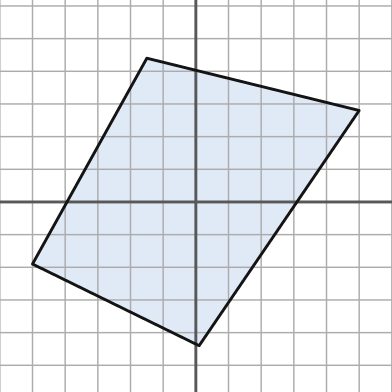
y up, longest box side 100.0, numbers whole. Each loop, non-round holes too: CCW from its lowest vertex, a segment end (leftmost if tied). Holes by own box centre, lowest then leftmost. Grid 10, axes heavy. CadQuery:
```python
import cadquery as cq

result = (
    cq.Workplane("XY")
    .moveTo(1.0, -44.0)
    .lineTo(50.0, 28.0)
    .lineTo(-15.0, 44.0)
    .lineTo(-50.0, -19.0)
    .close()
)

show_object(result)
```